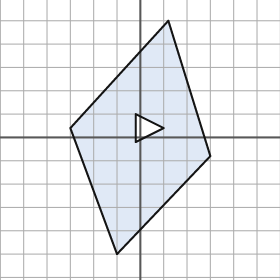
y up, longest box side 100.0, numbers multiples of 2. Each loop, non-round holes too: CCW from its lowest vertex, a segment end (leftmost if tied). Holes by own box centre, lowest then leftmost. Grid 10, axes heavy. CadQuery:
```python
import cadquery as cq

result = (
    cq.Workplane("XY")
    .moveTo(-10.0, -50.0)
    .lineTo(30.0, -8.0)
    .lineTo(12.0, 50.0)
    .lineTo(-30.0, 4.0)
    .close()
    .moveTo(-2.0, -2.0)
    .lineTo(10.0, 4.0)
    .lineTo(-2.0, 10.0)
    .close()
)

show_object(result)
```